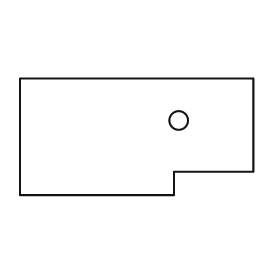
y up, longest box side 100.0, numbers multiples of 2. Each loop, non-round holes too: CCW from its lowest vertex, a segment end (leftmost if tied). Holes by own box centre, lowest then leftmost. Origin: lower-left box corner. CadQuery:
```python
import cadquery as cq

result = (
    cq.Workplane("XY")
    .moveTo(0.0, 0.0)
    .lineTo(66.0, 0.0)
    .lineTo(66.0, 10.0)
    .lineTo(100.0, 10.0)
    .lineTo(100.0, 50.0)
    .lineTo(0.0, 50.0)
    .close()
    .moveTo(68.0, 32.0)
    .circle(4.0)
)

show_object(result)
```